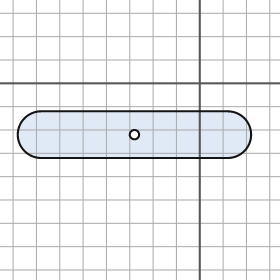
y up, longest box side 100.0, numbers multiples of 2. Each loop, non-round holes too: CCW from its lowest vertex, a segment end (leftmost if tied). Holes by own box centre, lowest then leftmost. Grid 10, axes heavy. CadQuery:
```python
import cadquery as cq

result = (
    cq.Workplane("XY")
    .moveTo(-68.0, -32.0)
    .lineTo(12.0, -32.0)
    .threePointArc((22.0, -22.0), (12.0, -12.0))
    .lineTo(-68.0, -12.0)
    .threePointArc((-78.0, -22.0), (-68.0, -32.0))
    .close()
    .moveTo(-28.0, -22.0)
    .circle(2.0)
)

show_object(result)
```